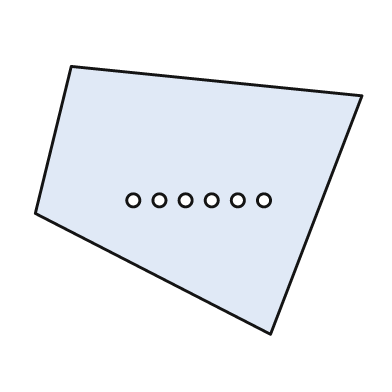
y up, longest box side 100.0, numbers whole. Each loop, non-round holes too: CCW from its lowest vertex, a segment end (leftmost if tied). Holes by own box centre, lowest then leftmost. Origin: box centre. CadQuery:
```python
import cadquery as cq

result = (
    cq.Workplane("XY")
    .moveTo(22.0, -41.0)
    .lineTo(50.0, 32.0)
    .lineTo(-39.0, 41.0)
    .lineTo(-50.0, -4.0)
    .close()
    .moveTo(-20.0, 0.0)
    .circle(2.0)
    .moveTo(-12.0, 0.0)
    .circle(2.0)
    .moveTo(-4.0, 0.0)
    .circle(2.0)
    .moveTo(4.0, 0.0)
    .circle(2.0)
    .moveTo(12.0, 0.0)
    .circle(2.0)
    .moveTo(20.0, 0.0)
    .circle(2.0)
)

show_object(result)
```